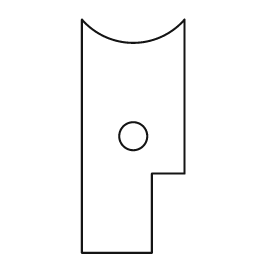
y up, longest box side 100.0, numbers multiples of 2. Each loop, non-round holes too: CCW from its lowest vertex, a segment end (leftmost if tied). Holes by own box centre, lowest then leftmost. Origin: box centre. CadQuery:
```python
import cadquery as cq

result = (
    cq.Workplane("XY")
    .moveTo(-22.0, -50.0)
    .lineTo(8.0, -50.0)
    .lineTo(8.0, -16.0)
    .lineTo(22.0, -16.0)
    .lineTo(22.0, 50.0)
    .threePointArc((0.0, 40.0), (-22.0, 50.0))
    .close()
    .moveTo(0.0, 0.0)
    .circle(6.0)
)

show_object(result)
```